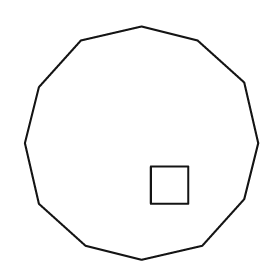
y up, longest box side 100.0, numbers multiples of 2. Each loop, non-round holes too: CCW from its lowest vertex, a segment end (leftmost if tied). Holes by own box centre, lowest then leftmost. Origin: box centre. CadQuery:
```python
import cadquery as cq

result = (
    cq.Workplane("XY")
    .moveTo(0.0, -50.0)
    .lineTo(26.0, -44.0)
    .lineTo(44.0, -24.0)
    .lineTo(50.0, 0.0)
    .lineTo(44.0, 26.0)
    .lineTo(24.0, 44.0)
    .lineTo(0.0, 50.0)
    .lineTo(-26.0, 44.0)
    .lineTo(-44.0, 24.0)
    .lineTo(-50.0, 0.0)
    .lineTo(-44.0, -26.0)
    .lineTo(-24.0, -44.0)
    .close()
    .moveTo(4.0, -26.0)
    .lineTo(20.0, -26.0)
    .lineTo(20.0, -10.0)
    .lineTo(4.0, -10.0)
    .close()
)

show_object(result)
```